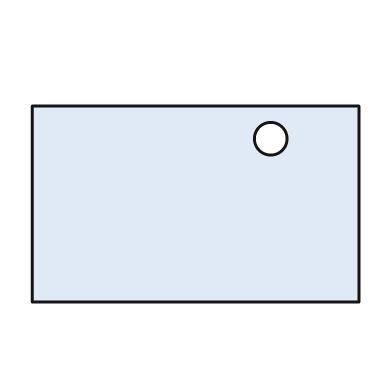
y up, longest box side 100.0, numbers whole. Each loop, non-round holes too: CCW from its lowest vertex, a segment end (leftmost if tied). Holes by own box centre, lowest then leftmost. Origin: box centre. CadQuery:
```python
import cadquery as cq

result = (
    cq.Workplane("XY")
    .moveTo(-50.0, -30.0)
    .lineTo(50.0, -30.0)
    .lineTo(50.0, 30.0)
    .lineTo(-50.0, 30.0)
    .close()
    .moveTo(23.0, 20.0)
    .circle(5.0)
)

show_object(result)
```